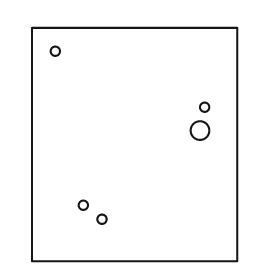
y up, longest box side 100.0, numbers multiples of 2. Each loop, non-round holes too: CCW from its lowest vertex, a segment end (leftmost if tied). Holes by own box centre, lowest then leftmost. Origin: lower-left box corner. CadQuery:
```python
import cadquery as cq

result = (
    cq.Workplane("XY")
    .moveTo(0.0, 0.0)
    .lineTo(88.0, 0.0)
    .lineTo(88.0, 100.0)
    .lineTo(0.0, 100.0)
    .close()
    .moveTo(30.0, 18.0)
    .circle(2.0)
    .moveTo(22.0, 24.0)
    .circle(2.0)
    .moveTo(72.0, 56.0)
    .circle(4.0)
    .moveTo(74.0, 66.0)
    .circle(2.0)
    .moveTo(10.0, 90.0)
    .circle(2.0)
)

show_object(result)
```